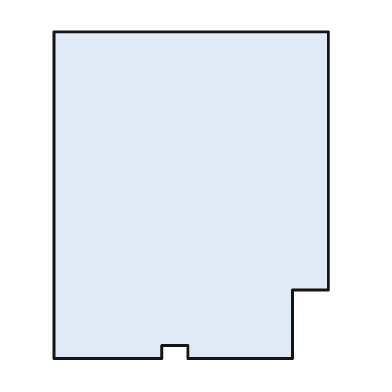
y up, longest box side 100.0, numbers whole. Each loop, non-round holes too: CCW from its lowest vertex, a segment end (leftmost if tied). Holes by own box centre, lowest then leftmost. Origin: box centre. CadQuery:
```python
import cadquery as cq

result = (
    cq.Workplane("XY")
    .moveTo(-42.0, -50.0)
    .lineTo(-9.0, -50.0)
    .lineTo(-9.0, -46.0)
    .lineTo(-1.0, -46.0)
    .lineTo(-1.0, -50.0)
    .lineTo(31.0, -50.0)
    .lineTo(31.0, -29.0)
    .lineTo(42.0, -29.0)
    .lineTo(42.0, 50.0)
    .lineTo(-42.0, 50.0)
    .close()
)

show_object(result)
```